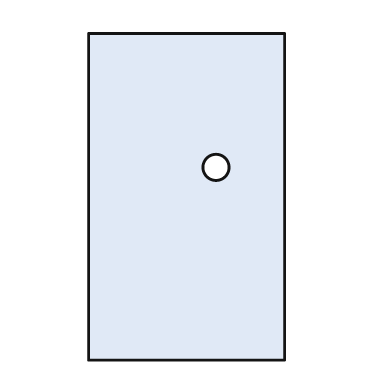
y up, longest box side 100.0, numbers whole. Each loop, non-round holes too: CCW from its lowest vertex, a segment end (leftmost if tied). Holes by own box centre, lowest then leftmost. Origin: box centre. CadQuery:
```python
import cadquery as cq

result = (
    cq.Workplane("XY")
    .moveTo(-30.0, -50.0)
    .lineTo(30.0, -50.0)
    .lineTo(30.0, 50.0)
    .lineTo(-30.0, 50.0)
    .close()
    .moveTo(9.0, 9.0)
    .circle(4.0)
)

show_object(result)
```